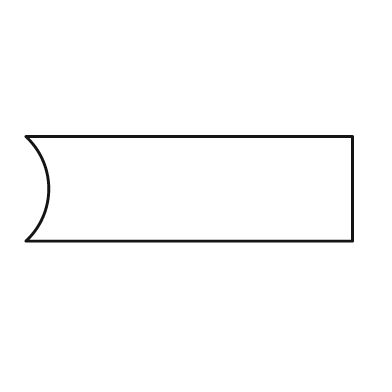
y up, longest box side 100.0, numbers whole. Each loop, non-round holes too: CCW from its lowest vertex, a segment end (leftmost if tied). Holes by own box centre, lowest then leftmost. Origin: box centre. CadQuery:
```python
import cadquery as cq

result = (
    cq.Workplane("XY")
    .moveTo(-50.0, -16.0)
    .lineTo(50.0, -16.0)
    .lineTo(50.0, 16.0)
    .lineTo(-50.0, 16.0)
    .threePointArc((-43.0, 0.0), (-50.0, -16.0))
    .close()
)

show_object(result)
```